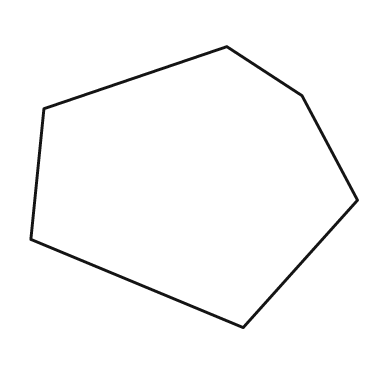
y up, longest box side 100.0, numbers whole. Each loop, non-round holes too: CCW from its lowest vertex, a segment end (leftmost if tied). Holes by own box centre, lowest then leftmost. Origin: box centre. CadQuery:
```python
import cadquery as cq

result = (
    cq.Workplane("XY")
    .moveTo(15.0, -43.0)
    .lineTo(50.0, -4.0)
    .lineTo(33.0, 28.0)
    .lineTo(10.0, 43.0)
    .lineTo(-46.0, 24.0)
    .lineTo(-50.0, -16.0)
    .close()
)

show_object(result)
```